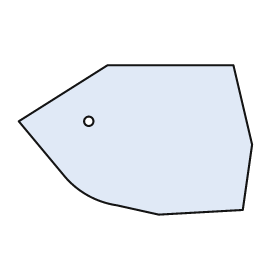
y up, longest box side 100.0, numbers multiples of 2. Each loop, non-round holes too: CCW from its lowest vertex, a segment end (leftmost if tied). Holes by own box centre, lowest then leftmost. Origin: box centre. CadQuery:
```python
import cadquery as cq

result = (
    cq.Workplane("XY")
    .moveTo(10.0, -32.0)
    .lineTo(46.0, -30.0)
    .lineTo(50.0, -2.0)
    .lineTo(42.0, 32.0)
    .lineTo(-12.0, 32.0)
    .lineTo(-50.0, 8.0)
    .lineTo(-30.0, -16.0)
    .threePointArc((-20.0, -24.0), (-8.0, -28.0))
    .close()
    .moveTo(-20.0, 8.0)
    .circle(2.0)
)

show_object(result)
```